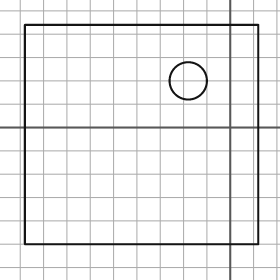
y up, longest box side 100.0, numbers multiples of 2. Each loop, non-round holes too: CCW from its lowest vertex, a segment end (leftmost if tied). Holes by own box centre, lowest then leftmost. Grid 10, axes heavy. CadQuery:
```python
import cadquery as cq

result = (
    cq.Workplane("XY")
    .moveTo(-88.0, -50.0)
    .lineTo(12.0, -50.0)
    .lineTo(12.0, 44.0)
    .lineTo(-88.0, 44.0)
    .close()
    .moveTo(-18.0, 20.0)
    .circle(8.0)
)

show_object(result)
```